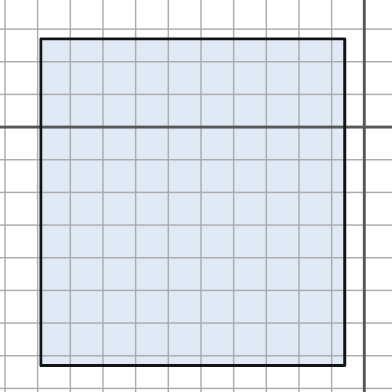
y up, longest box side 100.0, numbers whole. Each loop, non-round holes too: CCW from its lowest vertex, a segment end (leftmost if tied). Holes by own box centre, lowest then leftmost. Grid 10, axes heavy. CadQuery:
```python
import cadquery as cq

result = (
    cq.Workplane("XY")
    .moveTo(-99.0, -73.0)
    .lineTo(-6.0, -73.0)
    .lineTo(-6.0, 27.0)
    .lineTo(-99.0, 27.0)
    .close()
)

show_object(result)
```